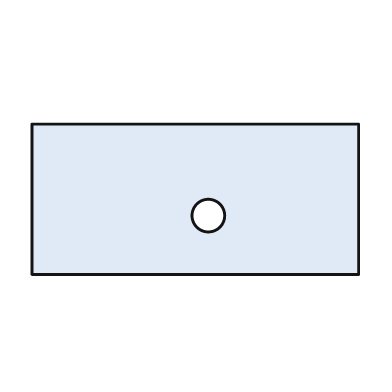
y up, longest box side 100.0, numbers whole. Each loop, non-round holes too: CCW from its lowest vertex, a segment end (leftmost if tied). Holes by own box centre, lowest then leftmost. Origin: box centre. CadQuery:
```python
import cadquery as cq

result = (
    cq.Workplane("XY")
    .moveTo(-50.0, -23.0)
    .lineTo(50.0, -23.0)
    .lineTo(50.0, 23.0)
    .lineTo(-50.0, 23.0)
    .close()
    .moveTo(4.0, -5.0)
    .circle(5.0)
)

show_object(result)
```